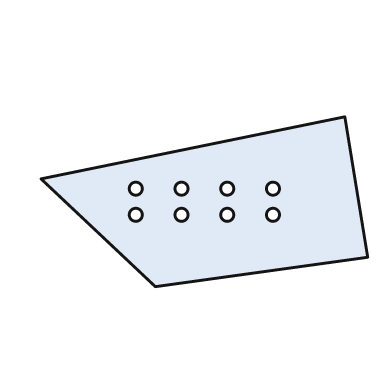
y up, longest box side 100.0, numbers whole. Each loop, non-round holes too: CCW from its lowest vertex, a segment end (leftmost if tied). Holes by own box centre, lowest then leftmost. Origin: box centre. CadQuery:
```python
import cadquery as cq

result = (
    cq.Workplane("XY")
    .moveTo(-15.0, -26.0)
    .lineTo(50.0, -17.0)
    .lineTo(43.0, 26.0)
    .lineTo(-50.0, 7.0)
    .close()
    .moveTo(-21.0, -4.0)
    .circle(2.0)
    .moveTo(-7.0, -4.0)
    .circle(2.0)
    .moveTo(7.0, -4.0)
    .circle(2.0)
    .moveTo(21.0, -4.0)
    .circle(2.0)
    .moveTo(-21.0, 4.0)
    .circle(2.0)
    .moveTo(-7.0, 4.0)
    .circle(2.0)
    .moveTo(7.0, 4.0)
    .circle(2.0)
    .moveTo(21.0, 4.0)
    .circle(2.0)
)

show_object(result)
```